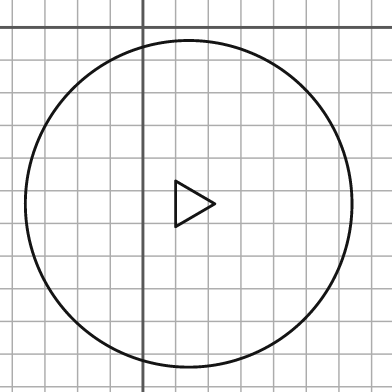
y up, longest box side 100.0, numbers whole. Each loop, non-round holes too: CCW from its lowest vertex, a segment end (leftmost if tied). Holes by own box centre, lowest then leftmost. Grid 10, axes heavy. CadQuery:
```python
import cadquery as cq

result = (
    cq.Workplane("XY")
    .moveTo(14.0, -54.0)
    .circle(50.0)
    .moveTo(10.0, -61.0)
    .lineTo(22.0, -54.0)
    .lineTo(10.0, -47.0)
    .close()
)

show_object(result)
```